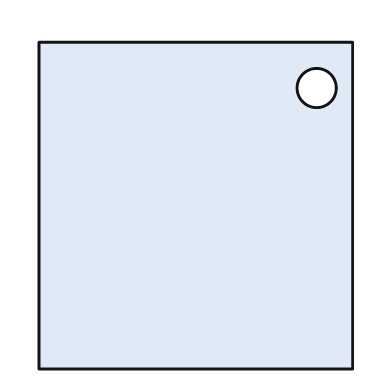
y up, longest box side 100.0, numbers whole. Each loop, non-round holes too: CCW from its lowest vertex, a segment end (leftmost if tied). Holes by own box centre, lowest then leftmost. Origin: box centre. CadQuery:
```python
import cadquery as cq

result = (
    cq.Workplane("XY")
    .moveTo(-48.0, -50.0)
    .lineTo(48.0, -50.0)
    .lineTo(48.0, 50.0)
    .lineTo(-48.0, 50.0)
    .close()
    .moveTo(37.0, 36.0)
    .circle(6.0)
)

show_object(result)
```